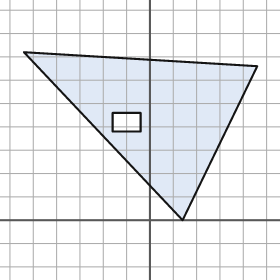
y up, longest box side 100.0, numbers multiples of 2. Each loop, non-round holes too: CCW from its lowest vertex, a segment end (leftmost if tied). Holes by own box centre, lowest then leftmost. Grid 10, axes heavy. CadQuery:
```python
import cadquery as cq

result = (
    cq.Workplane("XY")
    .moveTo(14.0, 0.0)
    .lineTo(46.0, 66.0)
    .lineTo(-54.0, 72.0)
    .close()
    .moveTo(-16.0, 38.0)
    .lineTo(-4.0, 38.0)
    .lineTo(-4.0, 46.0)
    .lineTo(-16.0, 46.0)
    .close()
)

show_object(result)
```